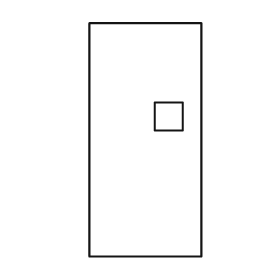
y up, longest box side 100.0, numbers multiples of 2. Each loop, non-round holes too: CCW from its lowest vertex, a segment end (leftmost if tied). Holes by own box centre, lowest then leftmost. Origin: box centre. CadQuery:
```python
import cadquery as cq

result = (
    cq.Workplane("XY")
    .moveTo(-24.0, -50.0)
    .lineTo(24.0, -50.0)
    .lineTo(24.0, 50.0)
    .lineTo(-24.0, 50.0)
    .close()
    .moveTo(4.0, 4.0)
    .lineTo(16.0, 4.0)
    .lineTo(16.0, 16.0)
    .lineTo(4.0, 16.0)
    .close()
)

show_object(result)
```